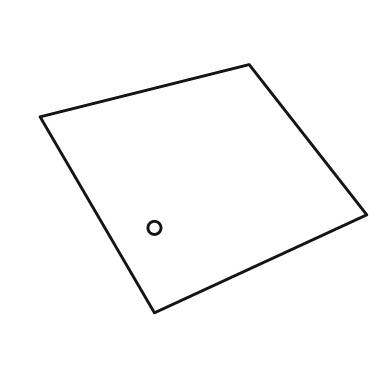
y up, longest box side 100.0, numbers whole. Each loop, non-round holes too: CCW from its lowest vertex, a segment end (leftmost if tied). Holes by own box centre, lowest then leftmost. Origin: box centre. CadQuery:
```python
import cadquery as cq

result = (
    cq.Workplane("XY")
    .moveTo(-15.0, -38.0)
    .lineTo(50.0, -8.0)
    .lineTo(14.0, 38.0)
    .lineTo(-50.0, 22.0)
    .close()
    .moveTo(-15.0, -12.0)
    .circle(2.0)
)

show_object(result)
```